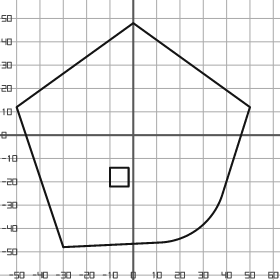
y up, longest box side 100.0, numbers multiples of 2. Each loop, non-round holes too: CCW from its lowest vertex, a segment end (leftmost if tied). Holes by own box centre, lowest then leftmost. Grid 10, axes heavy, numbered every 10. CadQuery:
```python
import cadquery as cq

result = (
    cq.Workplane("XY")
    .moveTo(-30.0, -48.0)
    .lineTo(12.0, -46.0)
    .threePointArc((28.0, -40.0), (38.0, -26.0))
    .lineTo(50.0, 12.0)
    .lineTo(0.0, 48.0)
    .lineTo(-50.0, 12.0)
    .close()
    .moveTo(-10.0, -22.0)
    .lineTo(-2.0, -22.0)
    .lineTo(-2.0, -14.0)
    .lineTo(-10.0, -14.0)
    .close()
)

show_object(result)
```